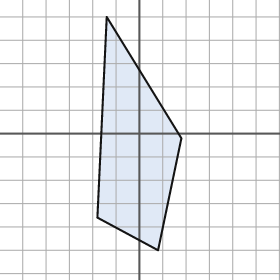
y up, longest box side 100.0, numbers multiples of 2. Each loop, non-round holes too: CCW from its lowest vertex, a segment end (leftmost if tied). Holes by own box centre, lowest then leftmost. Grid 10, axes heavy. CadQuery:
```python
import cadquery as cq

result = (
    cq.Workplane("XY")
    .moveTo(8.0, -50.0)
    .lineTo(18.0, -2.0)
    .lineTo(-14.0, 50.0)
    .lineTo(-18.0, -36.0)
    .close()
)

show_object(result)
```